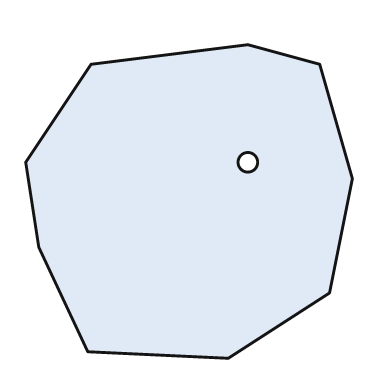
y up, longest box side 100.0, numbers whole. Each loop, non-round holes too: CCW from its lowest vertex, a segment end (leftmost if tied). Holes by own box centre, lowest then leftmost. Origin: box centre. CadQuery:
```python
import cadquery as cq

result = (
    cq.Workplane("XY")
    .moveTo(12.0, -48.0)
    .lineTo(43.0, -28.0)
    .lineTo(50.0, 7.0)
    .lineTo(40.0, 42.0)
    .lineTo(18.0, 48.0)
    .lineTo(-30.0, 42.0)
    .lineTo(-50.0, 12.0)
    .lineTo(-46.0, -14.0)
    .lineTo(-31.0, -46.0)
    .close()
    .moveTo(18.0, 12.0)
    .circle(3.0)
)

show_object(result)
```